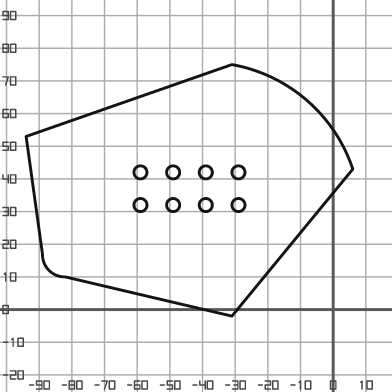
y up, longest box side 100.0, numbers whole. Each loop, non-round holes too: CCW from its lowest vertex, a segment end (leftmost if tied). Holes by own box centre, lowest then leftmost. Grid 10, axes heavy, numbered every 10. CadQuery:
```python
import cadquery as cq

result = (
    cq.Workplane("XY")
    .moveTo(-31.0, -2.0)
    .lineTo(6.0, 43.0)
    .threePointArc((-8.0, 64.0), (-31.0, 75.0))
    .lineTo(-94.0, 53.0)
    .lineTo(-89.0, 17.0)
    .threePointArc((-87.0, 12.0), (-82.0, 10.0))
    .close()
    .moveTo(-59.0, 32.0)
    .circle(2.0)
    .moveTo(-49.0, 32.0)
    .circle(2.0)
    .moveTo(-39.0, 32.0)
    .circle(2.0)
    .moveTo(-29.0, 32.0)
    .circle(2.0)
    .moveTo(-59.0, 42.0)
    .circle(2.0)
    .moveTo(-49.0, 42.0)
    .circle(2.0)
    .moveTo(-39.0, 42.0)
    .circle(2.0)
    .moveTo(-29.0, 42.0)
    .circle(2.0)
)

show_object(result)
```